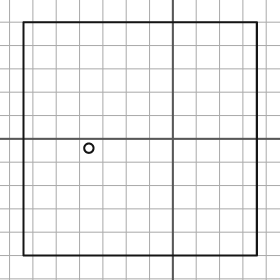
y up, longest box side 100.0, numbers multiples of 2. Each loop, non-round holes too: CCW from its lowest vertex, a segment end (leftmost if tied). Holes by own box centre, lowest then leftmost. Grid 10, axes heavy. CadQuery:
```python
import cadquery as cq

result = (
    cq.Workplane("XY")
    .moveTo(-64.0, -50.0)
    .lineTo(36.0, -50.0)
    .lineTo(36.0, 50.0)
    .lineTo(-64.0, 50.0)
    .close()
    .moveTo(-36.0, -4.0)
    .circle(2.0)
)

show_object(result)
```